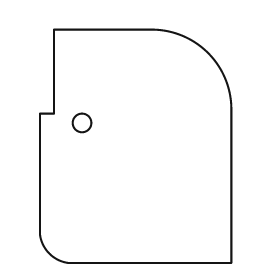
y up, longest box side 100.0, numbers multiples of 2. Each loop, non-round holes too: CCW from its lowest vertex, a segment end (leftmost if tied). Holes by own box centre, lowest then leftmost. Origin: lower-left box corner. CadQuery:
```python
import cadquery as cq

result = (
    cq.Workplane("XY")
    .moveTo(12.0, 0.0)
    .lineTo(82.0, 0.0)
    .lineTo(82.0, 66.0)
    .threePointArc((72.0, 90.0), (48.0, 100.0))
    .lineTo(6.0, 100.0)
    .lineTo(6.0, 64.0)
    .lineTo(0.0, 64.0)
    .lineTo(0.0, 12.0)
    .threePointArc((4.0, 4.0), (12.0, 0.0))
    .close()
    .moveTo(18.0, 60.0)
    .circle(4.0)
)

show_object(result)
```